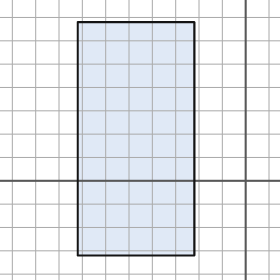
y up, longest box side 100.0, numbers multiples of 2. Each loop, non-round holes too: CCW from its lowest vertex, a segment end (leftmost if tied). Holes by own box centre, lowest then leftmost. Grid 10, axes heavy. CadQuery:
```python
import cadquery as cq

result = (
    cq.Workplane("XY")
    .moveTo(-72.0, -32.0)
    .lineTo(-22.0, -32.0)
    .lineTo(-22.0, 68.0)
    .lineTo(-72.0, 68.0)
    .close()
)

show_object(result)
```